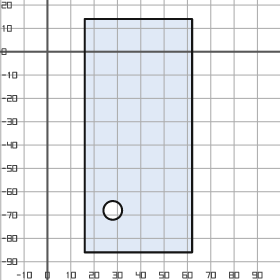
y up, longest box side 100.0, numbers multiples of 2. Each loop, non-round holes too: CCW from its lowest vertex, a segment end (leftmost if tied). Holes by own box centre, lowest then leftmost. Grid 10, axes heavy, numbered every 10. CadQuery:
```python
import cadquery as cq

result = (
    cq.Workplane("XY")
    .moveTo(16.0, -86.0)
    .lineTo(62.0, -86.0)
    .lineTo(62.0, 14.0)
    .lineTo(16.0, 14.0)
    .close()
    .moveTo(28.0, -68.0)
    .circle(4.0)
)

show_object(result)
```